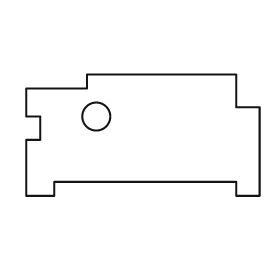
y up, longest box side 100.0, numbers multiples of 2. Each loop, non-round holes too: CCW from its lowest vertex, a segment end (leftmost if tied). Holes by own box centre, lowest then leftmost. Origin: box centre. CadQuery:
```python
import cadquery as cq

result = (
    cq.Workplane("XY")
    .moveTo(-50.0, -26.0)
    .lineTo(-38.0, -26.0)
    .lineTo(-38.0, -20.0)
    .lineTo(40.0, -20.0)
    .lineTo(40.0, -26.0)
    .lineTo(50.0, -26.0)
    .lineTo(50.0, 12.0)
    .lineTo(40.0, 12.0)
    .lineTo(40.0, 26.0)
    .lineTo(-24.0, 26.0)
    .lineTo(-24.0, 20.0)
    .lineTo(-50.0, 20.0)
    .lineTo(-50.0, 8.0)
    .lineTo(-44.0, 8.0)
    .lineTo(-44.0, -2.0)
    .lineTo(-50.0, -2.0)
    .close()
    .moveTo(-20.0, 8.0)
    .circle(6.0)
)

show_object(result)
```